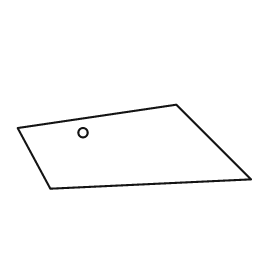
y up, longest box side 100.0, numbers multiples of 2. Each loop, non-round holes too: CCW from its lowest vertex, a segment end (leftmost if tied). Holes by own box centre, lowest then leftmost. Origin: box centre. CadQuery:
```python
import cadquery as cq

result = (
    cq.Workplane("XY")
    .moveTo(-36.0, -18.0)
    .lineTo(50.0, -14.0)
    .lineTo(18.0, 18.0)
    .lineTo(-50.0, 8.0)
    .close()
    .moveTo(-22.0, 6.0)
    .circle(2.0)
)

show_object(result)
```